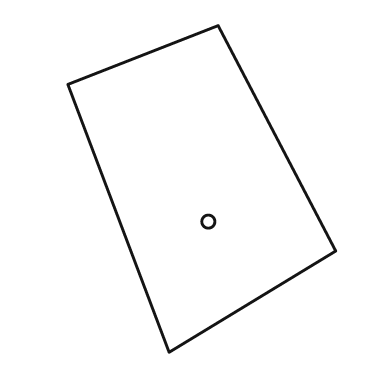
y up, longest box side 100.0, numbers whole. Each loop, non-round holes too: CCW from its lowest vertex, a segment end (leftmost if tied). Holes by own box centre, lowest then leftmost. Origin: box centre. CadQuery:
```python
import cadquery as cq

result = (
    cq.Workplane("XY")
    .moveTo(-10.0, -50.0)
    .lineTo(41.0, -19.0)
    .lineTo(5.0, 50.0)
    .lineTo(-41.0, 32.0)
    .close()
    .moveTo(2.0, -10.0)
    .circle(2.0)
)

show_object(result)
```